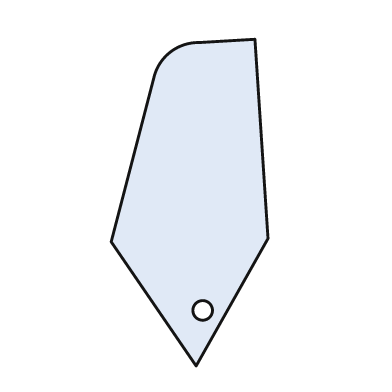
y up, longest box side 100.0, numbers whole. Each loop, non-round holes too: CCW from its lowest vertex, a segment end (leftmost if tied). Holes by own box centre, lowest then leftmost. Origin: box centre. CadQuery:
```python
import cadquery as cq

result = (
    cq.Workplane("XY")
    .moveTo(2.0, -50.0)
    .lineTo(24.0, -11.0)
    .lineTo(20.0, 50.0)
    .lineTo(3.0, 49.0)
    .threePointArc((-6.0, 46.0), (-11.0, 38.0))
    .lineTo(-24.0, -12.0)
    .close()
    .moveTo(4.0, -33.0)
    .circle(3.0)
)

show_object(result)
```